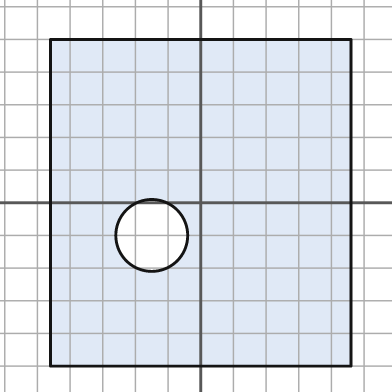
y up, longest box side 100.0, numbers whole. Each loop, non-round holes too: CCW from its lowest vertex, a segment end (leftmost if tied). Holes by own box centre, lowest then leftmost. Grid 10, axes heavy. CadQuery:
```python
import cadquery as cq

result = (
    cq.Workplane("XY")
    .moveTo(-46.0, -50.0)
    .lineTo(46.0, -50.0)
    .lineTo(46.0, 50.0)
    .lineTo(-46.0, 50.0)
    .close()
    .moveTo(-15.0, -10.0)
    .circle(11.0)
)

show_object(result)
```